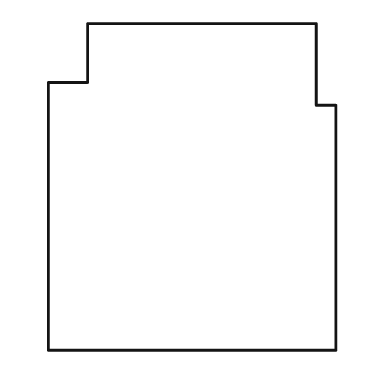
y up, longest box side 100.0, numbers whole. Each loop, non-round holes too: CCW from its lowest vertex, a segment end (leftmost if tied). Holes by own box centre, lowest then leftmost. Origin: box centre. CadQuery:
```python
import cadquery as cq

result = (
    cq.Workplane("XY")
    .moveTo(-44.0, -50.0)
    .lineTo(44.0, -50.0)
    .lineTo(44.0, 25.0)
    .lineTo(38.0, 25.0)
    .lineTo(38.0, 50.0)
    .lineTo(-32.0, 50.0)
    .lineTo(-32.0, 32.0)
    .lineTo(-44.0, 32.0)
    .close()
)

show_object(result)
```